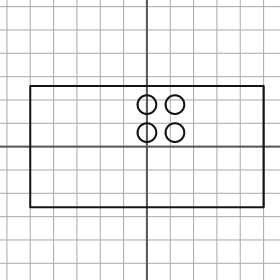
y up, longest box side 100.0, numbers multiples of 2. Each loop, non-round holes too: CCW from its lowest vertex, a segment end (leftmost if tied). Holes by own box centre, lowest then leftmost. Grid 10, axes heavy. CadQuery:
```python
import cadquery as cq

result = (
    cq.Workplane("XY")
    .moveTo(-50.0, -26.0)
    .lineTo(50.0, -26.0)
    .lineTo(50.0, 26.0)
    .lineTo(-50.0, 26.0)
    .close()
    .moveTo(0.0, 6.0)
    .circle(4.0)
    .moveTo(12.0, 6.0)
    .circle(4.0)
    .moveTo(0.0, 18.0)
    .circle(4.0)
    .moveTo(12.0, 18.0)
    .circle(4.0)
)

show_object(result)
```